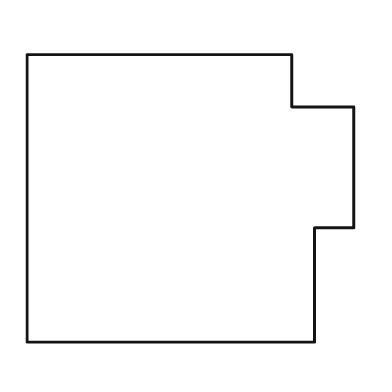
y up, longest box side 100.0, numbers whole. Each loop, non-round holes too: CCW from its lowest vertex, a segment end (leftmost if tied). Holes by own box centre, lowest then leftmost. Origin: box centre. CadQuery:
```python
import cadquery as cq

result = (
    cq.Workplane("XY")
    .moveTo(-50.0, -44.0)
    .lineTo(38.0, -44.0)
    .lineTo(38.0, -9.0)
    .lineTo(50.0, -9.0)
    .lineTo(50.0, 28.0)
    .lineTo(31.0, 28.0)
    .lineTo(31.0, 44.0)
    .lineTo(-50.0, 44.0)
    .close()
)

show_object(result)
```